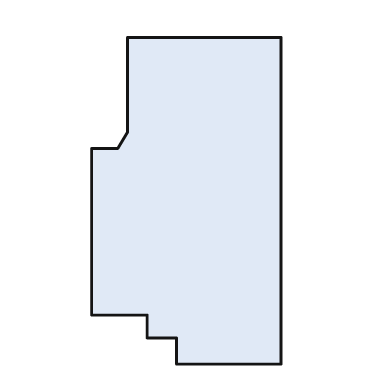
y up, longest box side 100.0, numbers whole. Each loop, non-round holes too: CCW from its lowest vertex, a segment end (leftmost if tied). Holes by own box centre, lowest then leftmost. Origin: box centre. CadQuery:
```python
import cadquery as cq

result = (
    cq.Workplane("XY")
    .moveTo(-3.0, -50.0)
    .lineTo(29.0, -50.0)
    .lineTo(29.0, 50.0)
    .lineTo(-18.0, 50.0)
    .lineTo(-18.0, 21.0)
    .lineTo(-21.0, 16.0)
    .lineTo(-29.0, 16.0)
    .lineTo(-29.0, -35.0)
    .lineTo(-12.0, -35.0)
    .lineTo(-12.0, -42.0)
    .lineTo(-3.0, -42.0)
    .close()
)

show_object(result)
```